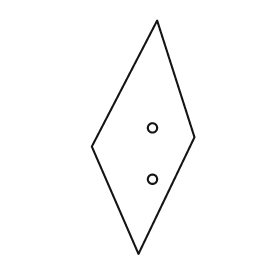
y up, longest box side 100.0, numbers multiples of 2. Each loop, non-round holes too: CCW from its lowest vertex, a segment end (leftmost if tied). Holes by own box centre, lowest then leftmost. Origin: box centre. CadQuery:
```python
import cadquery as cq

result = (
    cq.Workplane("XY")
    .moveTo(-2.0, -50.0)
    .lineTo(22.0, 0.0)
    .lineTo(6.0, 50.0)
    .lineTo(-22.0, -4.0)
    .close()
    .moveTo(4.0, -18.0)
    .circle(2.0)
    .moveTo(4.0, 4.0)
    .circle(2.0)
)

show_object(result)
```